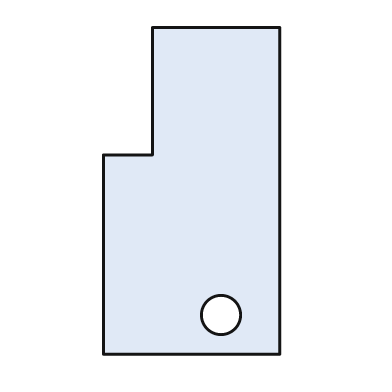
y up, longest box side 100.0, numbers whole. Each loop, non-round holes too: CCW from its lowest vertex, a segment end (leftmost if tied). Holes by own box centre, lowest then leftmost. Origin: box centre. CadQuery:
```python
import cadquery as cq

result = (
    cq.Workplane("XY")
    .moveTo(-27.0, -50.0)
    .lineTo(27.0, -50.0)
    .lineTo(27.0, 50.0)
    .lineTo(-12.0, 50.0)
    .lineTo(-12.0, 11.0)
    .lineTo(-27.0, 11.0)
    .close()
    .moveTo(9.0, -38.0)
    .circle(6.0)
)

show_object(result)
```